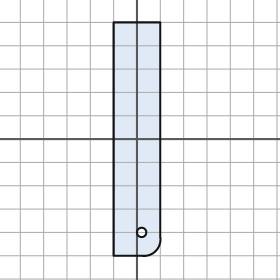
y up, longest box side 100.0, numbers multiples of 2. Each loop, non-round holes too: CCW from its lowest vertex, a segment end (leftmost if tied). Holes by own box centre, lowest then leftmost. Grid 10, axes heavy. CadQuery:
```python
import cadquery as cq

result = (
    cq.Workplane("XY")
    .moveTo(-10.0, -50.0)
    .lineTo(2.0, -50.0)
    .threePointArc((8.0, -48.0), (10.0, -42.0))
    .lineTo(10.0, 50.0)
    .lineTo(-10.0, 50.0)
    .close()
    .moveTo(2.0, -40.0)
    .circle(2.0)
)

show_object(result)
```